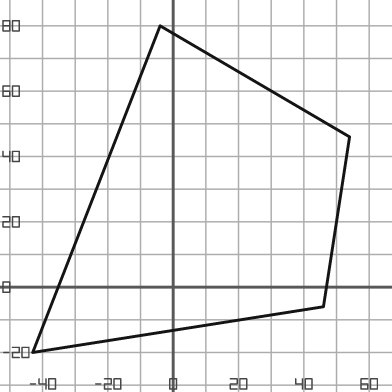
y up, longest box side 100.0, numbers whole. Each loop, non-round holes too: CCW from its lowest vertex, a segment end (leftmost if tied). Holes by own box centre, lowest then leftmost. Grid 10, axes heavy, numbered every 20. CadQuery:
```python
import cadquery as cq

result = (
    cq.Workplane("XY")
    .moveTo(-43.0, -20.0)
    .lineTo(46.0, -6.0)
    .lineTo(54.0, 46.0)
    .lineTo(-4.0, 80.0)
    .close()
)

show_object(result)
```